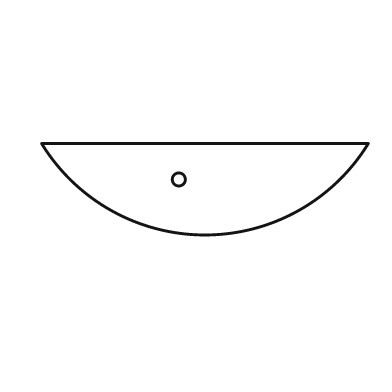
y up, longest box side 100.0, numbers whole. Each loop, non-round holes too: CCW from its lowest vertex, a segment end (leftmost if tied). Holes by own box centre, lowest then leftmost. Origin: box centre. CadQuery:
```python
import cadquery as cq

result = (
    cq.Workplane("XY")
    .moveTo(-50.0, 14.0)
    .threePointArc((0.0, -14.0), (50.0, 14.0))
    .close()
    .moveTo(-8.0, 3.0)
    .circle(2.0)
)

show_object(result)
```